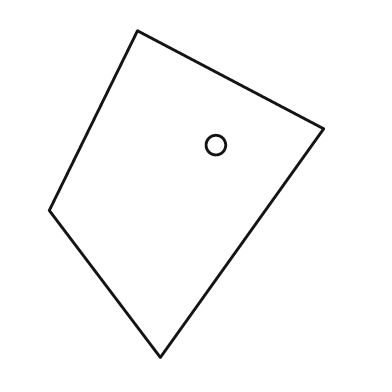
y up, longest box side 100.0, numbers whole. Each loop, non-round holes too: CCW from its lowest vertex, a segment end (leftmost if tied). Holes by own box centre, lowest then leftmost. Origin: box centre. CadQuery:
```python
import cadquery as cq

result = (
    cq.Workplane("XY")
    .moveTo(-8.0, -50.0)
    .lineTo(42.0, 20.0)
    .lineTo(-15.0, 50.0)
    .lineTo(-42.0, -5.0)
    .close()
    .moveTo(9.0, 15.0)
    .circle(3.0)
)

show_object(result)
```